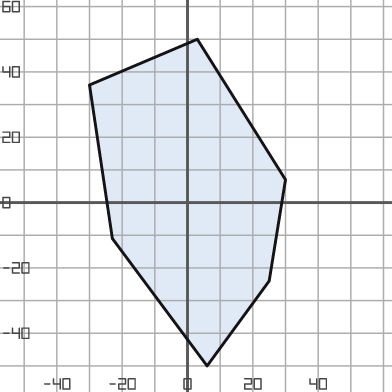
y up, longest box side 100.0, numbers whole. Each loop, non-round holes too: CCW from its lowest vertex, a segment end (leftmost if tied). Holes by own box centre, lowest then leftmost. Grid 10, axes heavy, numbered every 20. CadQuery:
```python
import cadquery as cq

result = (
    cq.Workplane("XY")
    .moveTo(6.0, -50.0)
    .lineTo(25.0, -24.0)
    .lineTo(30.0, 7.0)
    .lineTo(3.0, 50.0)
    .lineTo(-30.0, 36.0)
    .lineTo(-23.0, -11.0)
    .close()
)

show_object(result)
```